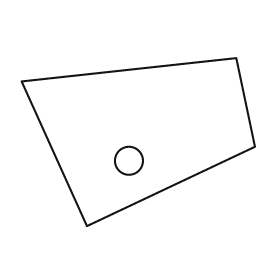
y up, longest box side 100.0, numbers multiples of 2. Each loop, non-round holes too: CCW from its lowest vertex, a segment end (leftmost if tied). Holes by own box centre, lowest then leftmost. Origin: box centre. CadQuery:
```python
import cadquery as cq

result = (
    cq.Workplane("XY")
    .moveTo(-22.0, -36.0)
    .lineTo(50.0, -2.0)
    .lineTo(42.0, 36.0)
    .lineTo(-50.0, 26.0)
    .close()
    .moveTo(-4.0, -8.0)
    .circle(6.0)
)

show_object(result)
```